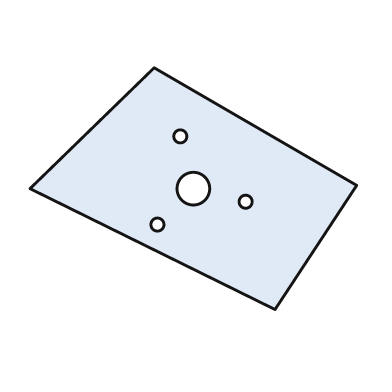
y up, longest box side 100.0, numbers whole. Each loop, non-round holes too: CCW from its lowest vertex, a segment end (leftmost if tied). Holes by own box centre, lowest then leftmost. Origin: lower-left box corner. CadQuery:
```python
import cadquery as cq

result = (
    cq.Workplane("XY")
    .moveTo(75.0, 0.0)
    .lineTo(100.0, 38.0)
    .lineTo(38.0, 74.0)
    .lineTo(0.0, 37.0)
    .close()
    .moveTo(39.0, 26.0)
    .circle(2.0)
    .moveTo(66.0, 33.0)
    .circle(2.0)
    .moveTo(50.0, 37.0)
    .circle(5.0)
    .moveTo(46.0, 53.0)
    .circle(2.0)
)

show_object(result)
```